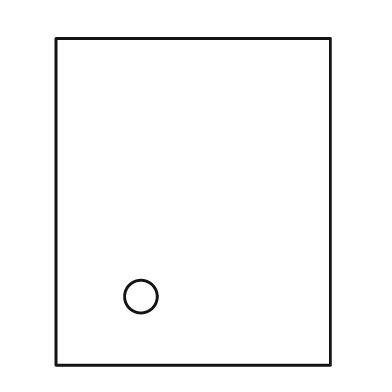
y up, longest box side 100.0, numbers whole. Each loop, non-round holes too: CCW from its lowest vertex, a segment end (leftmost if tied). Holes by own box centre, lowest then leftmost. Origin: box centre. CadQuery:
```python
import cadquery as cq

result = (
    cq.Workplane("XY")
    .moveTo(-42.0, -50.0)
    .lineTo(42.0, -50.0)
    .lineTo(42.0, 50.0)
    .lineTo(-42.0, 50.0)
    .close()
    .moveTo(-16.0, -29.0)
    .circle(5.0)
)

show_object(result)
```